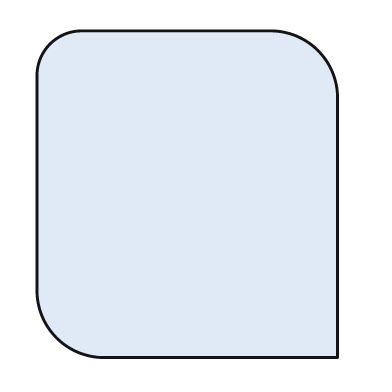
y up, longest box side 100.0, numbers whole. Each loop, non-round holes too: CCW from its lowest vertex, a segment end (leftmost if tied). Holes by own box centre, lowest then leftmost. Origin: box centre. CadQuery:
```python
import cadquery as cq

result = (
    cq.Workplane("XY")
    .moveTo(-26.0, -50.0)
    .lineTo(46.0, -50.0)
    .lineTo(46.0, 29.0)
    .threePointArc((40.0, 44.0), (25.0, 50.0))
    .lineTo(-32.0, 50.0)
    .threePointArc((-42.0, 46.0), (-46.0, 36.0))
    .lineTo(-46.0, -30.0)
    .threePointArc((-40.0, -44.0), (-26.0, -50.0))
    .close()
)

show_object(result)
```